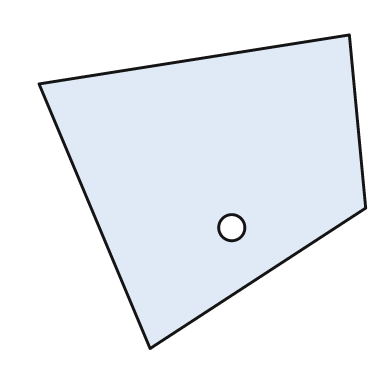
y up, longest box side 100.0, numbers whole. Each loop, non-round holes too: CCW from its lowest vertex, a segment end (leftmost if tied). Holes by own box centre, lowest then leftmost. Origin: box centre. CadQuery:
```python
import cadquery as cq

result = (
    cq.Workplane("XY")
    .moveTo(-16.0, -48.0)
    .lineTo(50.0, -5.0)
    .lineTo(45.0, 48.0)
    .lineTo(-50.0, 33.0)
    .close()
    .moveTo(9.0, -11.0)
    .circle(4.0)
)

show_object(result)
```